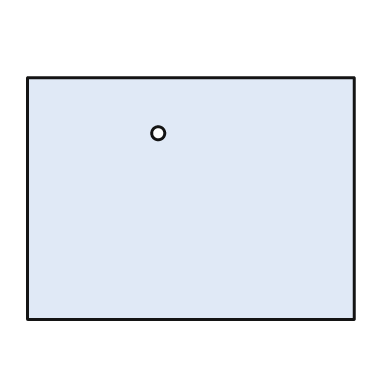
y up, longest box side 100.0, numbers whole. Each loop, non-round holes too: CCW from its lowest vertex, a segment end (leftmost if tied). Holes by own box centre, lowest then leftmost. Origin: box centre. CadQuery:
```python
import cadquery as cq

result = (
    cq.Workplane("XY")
    .moveTo(-50.0, -37.0)
    .lineTo(50.0, -37.0)
    .lineTo(50.0, 37.0)
    .lineTo(-50.0, 37.0)
    .close()
    .moveTo(-10.0, 20.0)
    .circle(2.0)
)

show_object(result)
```